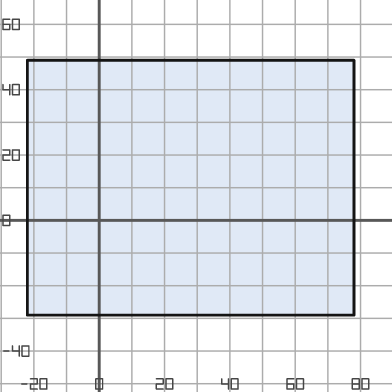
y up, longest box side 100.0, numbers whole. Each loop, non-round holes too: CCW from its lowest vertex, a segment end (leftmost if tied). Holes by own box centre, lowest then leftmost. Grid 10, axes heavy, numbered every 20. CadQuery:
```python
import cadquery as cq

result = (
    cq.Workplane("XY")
    .moveTo(-22.0, -29.0)
    .lineTo(78.0, -29.0)
    .lineTo(78.0, 49.0)
    .lineTo(-22.0, 49.0)
    .close()
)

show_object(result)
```